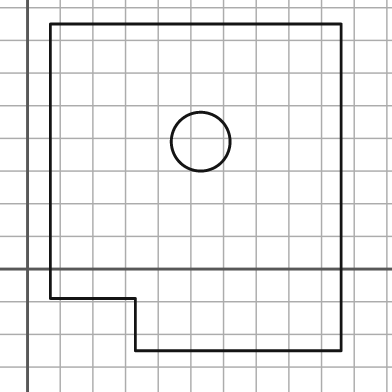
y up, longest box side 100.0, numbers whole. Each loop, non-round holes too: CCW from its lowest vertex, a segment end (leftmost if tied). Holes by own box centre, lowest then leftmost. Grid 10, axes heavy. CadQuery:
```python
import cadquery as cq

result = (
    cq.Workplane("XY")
    .moveTo(33.0, -25.0)
    .lineTo(96.0, -25.0)
    .lineTo(96.0, 75.0)
    .lineTo(7.0, 75.0)
    .lineTo(7.0, -9.0)
    .lineTo(33.0, -9.0)
    .close()
    .moveTo(53.0, 39.0)
    .circle(9.0)
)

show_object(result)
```